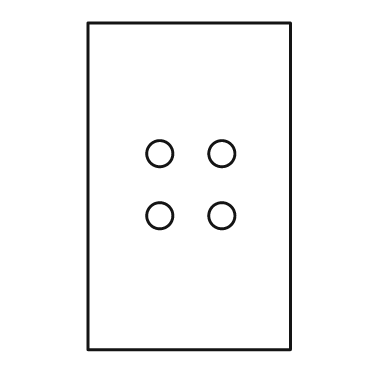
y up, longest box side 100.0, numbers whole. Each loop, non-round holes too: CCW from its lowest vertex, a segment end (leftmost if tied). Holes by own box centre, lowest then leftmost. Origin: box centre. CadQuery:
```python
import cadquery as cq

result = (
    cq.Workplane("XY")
    .moveTo(-31.0, -50.0)
    .lineTo(31.0, -50.0)
    .lineTo(31.0, 50.0)
    .lineTo(-31.0, 50.0)
    .close()
    .moveTo(-9.0, -9.0)
    .circle(4.0)
    .moveTo(10.0, -9.0)
    .circle(4.0)
    .moveTo(-9.0, 10.0)
    .circle(4.0)
    .moveTo(10.0, 10.0)
    .circle(4.0)
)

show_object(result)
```